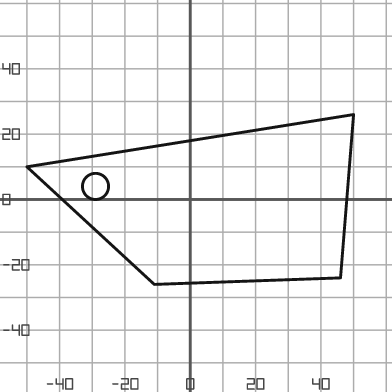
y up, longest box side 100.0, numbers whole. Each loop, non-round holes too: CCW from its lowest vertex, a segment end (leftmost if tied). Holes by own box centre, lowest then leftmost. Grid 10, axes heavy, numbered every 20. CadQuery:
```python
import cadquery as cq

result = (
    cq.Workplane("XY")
    .moveTo(-11.0, -26.0)
    .lineTo(46.0, -24.0)
    .lineTo(50.0, 26.0)
    .lineTo(-50.0, 10.0)
    .close()
    .moveTo(-29.0, 4.0)
    .circle(4.0)
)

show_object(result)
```